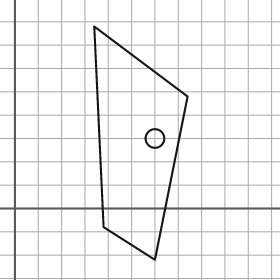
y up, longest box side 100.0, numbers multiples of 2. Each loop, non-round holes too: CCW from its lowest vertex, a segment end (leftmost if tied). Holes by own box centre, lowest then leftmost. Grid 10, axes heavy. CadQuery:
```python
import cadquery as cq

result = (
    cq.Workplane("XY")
    .moveTo(60.0, -22.0)
    .lineTo(74.0, 48.0)
    .lineTo(34.0, 78.0)
    .lineTo(38.0, -8.0)
    .close()
    .moveTo(60.0, 30.0)
    .circle(4.0)
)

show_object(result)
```